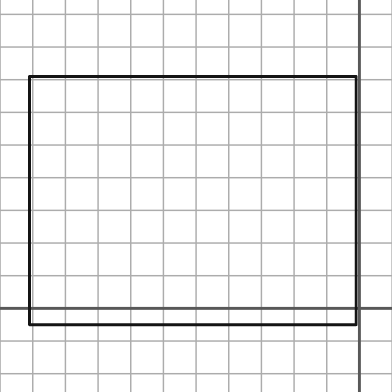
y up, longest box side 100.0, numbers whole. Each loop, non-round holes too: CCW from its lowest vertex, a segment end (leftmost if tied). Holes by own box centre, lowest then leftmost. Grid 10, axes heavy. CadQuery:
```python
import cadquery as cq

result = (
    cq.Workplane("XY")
    .moveTo(-101.0, -5.0)
    .lineTo(-1.0, -5.0)
    .lineTo(-1.0, 71.0)
    .lineTo(-101.0, 71.0)
    .close()
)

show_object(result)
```